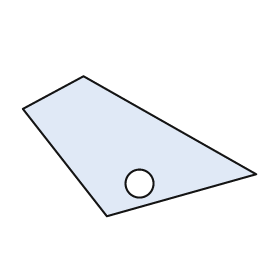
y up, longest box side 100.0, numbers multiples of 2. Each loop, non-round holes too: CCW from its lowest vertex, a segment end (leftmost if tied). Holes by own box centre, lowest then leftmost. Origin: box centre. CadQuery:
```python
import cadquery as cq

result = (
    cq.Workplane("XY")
    .moveTo(-14.0, -30.0)
    .lineTo(50.0, -12.0)
    .lineTo(-24.0, 30.0)
    .lineTo(-50.0, 16.0)
    .close()
    .moveTo(0.0, -16.0)
    .circle(6.0)
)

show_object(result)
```